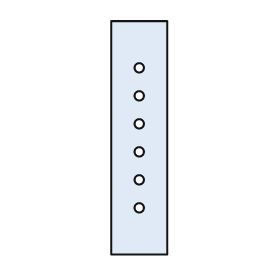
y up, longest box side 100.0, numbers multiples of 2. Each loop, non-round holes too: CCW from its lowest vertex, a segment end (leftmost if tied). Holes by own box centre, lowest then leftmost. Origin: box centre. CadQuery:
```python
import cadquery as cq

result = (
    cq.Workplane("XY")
    .moveTo(-12.0, -50.0)
    .lineTo(12.0, -50.0)
    .lineTo(12.0, 50.0)
    .lineTo(-12.0, 50.0)
    .close()
    .moveTo(0.0, -30.0)
    .circle(2.0)
    .moveTo(0.0, -18.0)
    .circle(2.0)
    .moveTo(0.0, -6.0)
    .circle(2.0)
    .moveTo(0.0, 6.0)
    .circle(2.0)
    .moveTo(0.0, 18.0)
    .circle(2.0)
    .moveTo(0.0, 30.0)
    .circle(2.0)
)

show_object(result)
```